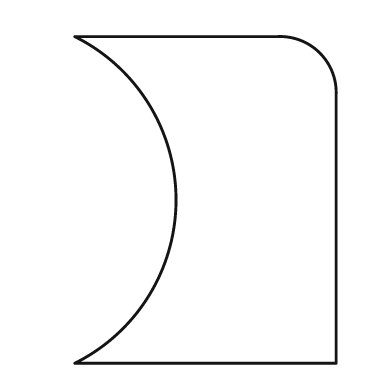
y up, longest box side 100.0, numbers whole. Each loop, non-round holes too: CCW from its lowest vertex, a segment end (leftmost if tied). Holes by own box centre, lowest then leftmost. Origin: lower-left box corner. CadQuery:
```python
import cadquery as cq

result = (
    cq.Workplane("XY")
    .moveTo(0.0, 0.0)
    .lineTo(80.0, 0.0)
    .lineTo(80.0, 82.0)
    .threePointArc((75.0, 95.0), (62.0, 100.0))
    .lineTo(0.0, 100.0)
    .threePointArc((31.0, 50.0), (0.0, 0.0))
    .close()
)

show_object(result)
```